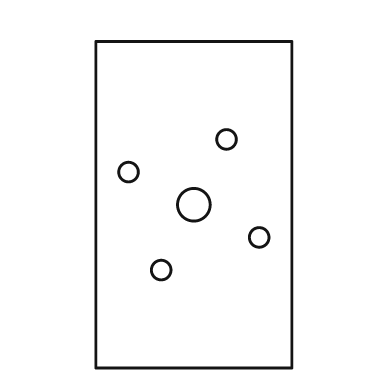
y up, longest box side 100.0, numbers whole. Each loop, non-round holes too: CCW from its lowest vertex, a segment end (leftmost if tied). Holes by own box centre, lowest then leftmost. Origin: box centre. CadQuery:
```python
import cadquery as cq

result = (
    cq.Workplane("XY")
    .moveTo(-30.0, -50.0)
    .lineTo(30.0, -50.0)
    .lineTo(30.0, 50.0)
    .lineTo(-30.0, 50.0)
    .close()
    .moveTo(-10.0, -20.0)
    .circle(3.0)
    .moveTo(20.0, -10.0)
    .circle(3.0)
    .moveTo(0.0, 0.0)
    .circle(5.0)
    .moveTo(-20.0, 10.0)
    .circle(3.0)
    .moveTo(10.0, 20.0)
    .circle(3.0)
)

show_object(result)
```